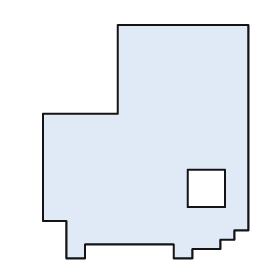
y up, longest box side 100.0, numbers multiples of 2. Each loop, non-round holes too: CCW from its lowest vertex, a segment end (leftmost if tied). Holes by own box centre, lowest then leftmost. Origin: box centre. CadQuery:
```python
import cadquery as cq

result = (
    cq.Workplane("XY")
    .moveTo(-34.0, -50.0)
    .lineTo(-26.0, -50.0)
    .lineTo(-26.0, -44.0)
    .lineTo(12.0, -44.0)
    .lineTo(12.0, -50.0)
    .lineTo(20.0, -50.0)
    .lineTo(20.0, -46.0)
    .lineTo(32.0, -46.0)
    .lineTo(32.0, -42.0)
    .lineTo(38.0, -42.0)
    .lineTo(38.0, -38.0)
    .lineTo(44.0, -38.0)
    .lineTo(44.0, 50.0)
    .lineTo(-12.0, 50.0)
    .lineTo(-12.0, 12.0)
    .lineTo(-44.0, 12.0)
    .lineTo(-44.0, -34.0)
    .lineTo(-34.0, -34.0)
    .close()
    .moveTo(18.0, -28.0)
    .lineTo(34.0, -28.0)
    .lineTo(34.0, -12.0)
    .lineTo(18.0, -12.0)
    .close()
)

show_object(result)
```